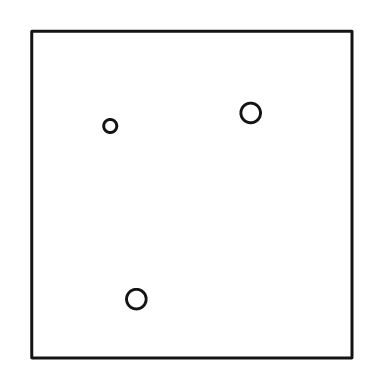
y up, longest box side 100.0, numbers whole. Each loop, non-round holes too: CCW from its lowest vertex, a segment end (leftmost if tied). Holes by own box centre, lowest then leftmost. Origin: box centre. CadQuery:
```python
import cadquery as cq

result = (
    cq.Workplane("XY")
    .moveTo(-49.0, -50.0)
    .lineTo(49.0, -50.0)
    .lineTo(49.0, 50.0)
    .lineTo(-49.0, 50.0)
    .close()
    .moveTo(-17.0, -32.0)
    .circle(3.0)
    .moveTo(-25.0, 21.0)
    .circle(2.0)
    .moveTo(18.0, 25.0)
    .circle(3.0)
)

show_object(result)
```